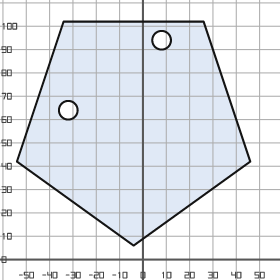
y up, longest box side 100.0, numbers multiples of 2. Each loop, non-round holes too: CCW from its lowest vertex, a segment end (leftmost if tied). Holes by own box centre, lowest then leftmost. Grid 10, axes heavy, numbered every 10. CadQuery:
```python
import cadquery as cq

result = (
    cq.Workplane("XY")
    .moveTo(-4.0, 6.0)
    .lineTo(46.0, 42.0)
    .lineTo(26.0, 102.0)
    .lineTo(-34.0, 102.0)
    .lineTo(-54.0, 42.0)
    .close()
    .moveTo(-32.0, 64.0)
    .circle(4.0)
    .moveTo(8.0, 94.0)
    .circle(4.0)
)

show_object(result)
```